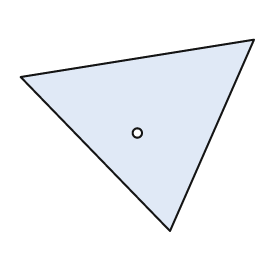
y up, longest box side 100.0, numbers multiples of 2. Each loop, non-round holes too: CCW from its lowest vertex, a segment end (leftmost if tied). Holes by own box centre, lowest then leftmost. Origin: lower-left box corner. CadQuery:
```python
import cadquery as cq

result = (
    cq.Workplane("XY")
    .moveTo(64.0, 0.0)
    .lineTo(100.0, 82.0)
    .lineTo(0.0, 66.0)
    .close()
    .moveTo(50.0, 42.0)
    .circle(2.0)
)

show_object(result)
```